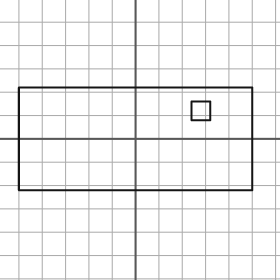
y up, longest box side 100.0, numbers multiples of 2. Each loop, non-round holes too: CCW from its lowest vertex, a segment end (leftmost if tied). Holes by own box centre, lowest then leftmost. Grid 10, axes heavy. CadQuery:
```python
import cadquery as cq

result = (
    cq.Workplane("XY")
    .moveTo(-50.0, -22.0)
    .lineTo(50.0, -22.0)
    .lineTo(50.0, 22.0)
    .lineTo(-50.0, 22.0)
    .close()
    .moveTo(24.0, 8.0)
    .lineTo(32.0, 8.0)
    .lineTo(32.0, 16.0)
    .lineTo(24.0, 16.0)
    .close()
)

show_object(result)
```